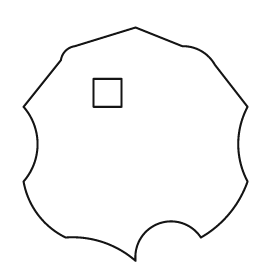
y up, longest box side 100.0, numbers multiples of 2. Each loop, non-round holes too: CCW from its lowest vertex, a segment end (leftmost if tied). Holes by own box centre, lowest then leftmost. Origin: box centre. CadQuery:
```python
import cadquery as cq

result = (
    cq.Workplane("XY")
    .moveTo(0.0, -50.0)
    .threePointArc((10.0, -34.0), (28.0, -40.0))
    .threePointArc((40.0, -30.0), (48.0, -16.0))
    .threePointArc((44.0, 0.0), (48.0, 16.0))
    .lineTo(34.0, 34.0)
    .threePointArc((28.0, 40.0), (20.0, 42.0))
    .lineTo(0.0, 50.0)
    .lineTo(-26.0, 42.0)
    .threePointArc((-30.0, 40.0), (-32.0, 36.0))
    .lineTo(-48.0, 16.0)
    .threePointArc((-42.0, 0.0), (-48.0, -16.0))
    .threePointArc((-42.0, -30.0), (-30.0, -40.0))
    .threePointArc((-14.0, -42.0), (0.0, -50.0))
    .close()
    .moveTo(-18.0, 16.0)
    .lineTo(-6.0, 16.0)
    .lineTo(-6.0, 28.0)
    .lineTo(-18.0, 28.0)
    .close()
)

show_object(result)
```